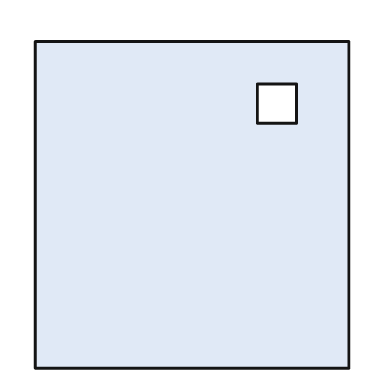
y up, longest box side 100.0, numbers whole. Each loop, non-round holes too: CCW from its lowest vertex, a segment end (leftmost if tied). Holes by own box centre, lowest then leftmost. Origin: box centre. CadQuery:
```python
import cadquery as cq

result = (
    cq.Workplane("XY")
    .moveTo(-48.0, -50.0)
    .lineTo(48.0, -50.0)
    .lineTo(48.0, 50.0)
    .lineTo(-48.0, 50.0)
    .close()
    .moveTo(20.0, 25.0)
    .lineTo(32.0, 25.0)
    .lineTo(32.0, 37.0)
    .lineTo(20.0, 37.0)
    .close()
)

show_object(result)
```